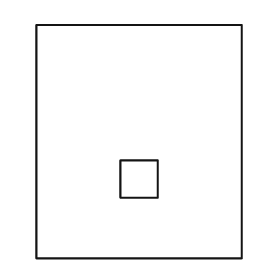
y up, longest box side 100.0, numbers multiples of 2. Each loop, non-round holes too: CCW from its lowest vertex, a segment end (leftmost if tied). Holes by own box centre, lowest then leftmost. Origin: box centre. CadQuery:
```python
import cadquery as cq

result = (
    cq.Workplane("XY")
    .moveTo(-44.0, -50.0)
    .lineTo(44.0, -50.0)
    .lineTo(44.0, 50.0)
    .lineTo(-44.0, 50.0)
    .close()
    .moveTo(-8.0, -24.0)
    .lineTo(8.0, -24.0)
    .lineTo(8.0, -8.0)
    .lineTo(-8.0, -8.0)
    .close()
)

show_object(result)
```